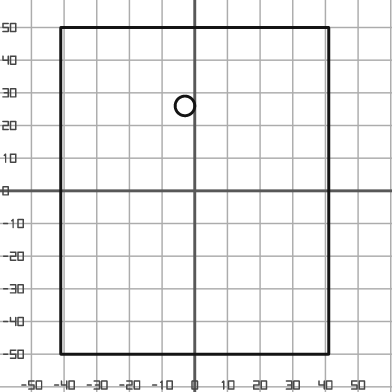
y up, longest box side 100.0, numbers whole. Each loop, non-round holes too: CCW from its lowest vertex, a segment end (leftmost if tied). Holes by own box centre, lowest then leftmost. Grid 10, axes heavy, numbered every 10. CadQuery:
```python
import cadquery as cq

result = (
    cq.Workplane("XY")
    .moveTo(-41.0, -50.0)
    .lineTo(41.0, -50.0)
    .lineTo(41.0, 50.0)
    .lineTo(-41.0, 50.0)
    .close()
    .moveTo(-3.0, 26.0)
    .circle(3.0)
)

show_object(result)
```